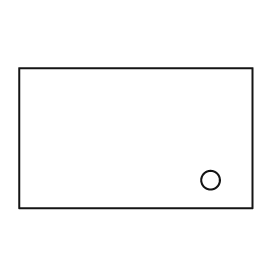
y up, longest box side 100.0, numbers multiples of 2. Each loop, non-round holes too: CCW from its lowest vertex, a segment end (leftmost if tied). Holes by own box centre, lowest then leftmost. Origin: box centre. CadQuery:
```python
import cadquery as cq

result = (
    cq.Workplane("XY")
    .moveTo(-50.0, -30.0)
    .lineTo(50.0, -30.0)
    .lineTo(50.0, 30.0)
    .lineTo(-50.0, 30.0)
    .close()
    .moveTo(32.0, -18.0)
    .circle(4.0)
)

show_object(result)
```